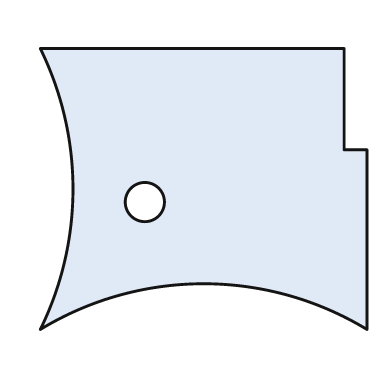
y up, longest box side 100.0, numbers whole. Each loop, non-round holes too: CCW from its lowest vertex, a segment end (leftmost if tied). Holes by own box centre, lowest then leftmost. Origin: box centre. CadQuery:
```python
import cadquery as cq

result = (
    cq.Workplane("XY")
    .moveTo(-50.0, -43.0)
    .threePointArc((0.0, -29.0), (50.0, -43.0))
    .lineTo(50.0, 12.0)
    .lineTo(43.0, 12.0)
    .lineTo(43.0, 43.0)
    .lineTo(-50.0, 43.0)
    .threePointArc((-40.0, 0.0), (-50.0, -43.0))
    .close()
    .moveTo(-18.0, -4.0)
    .circle(6.0)
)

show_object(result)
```